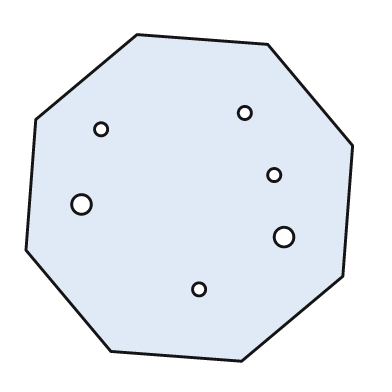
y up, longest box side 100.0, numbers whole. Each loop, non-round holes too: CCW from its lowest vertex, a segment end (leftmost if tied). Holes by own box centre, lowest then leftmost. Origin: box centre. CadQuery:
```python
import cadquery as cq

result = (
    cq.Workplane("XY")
    .moveTo(16.0, -50.0)
    .lineTo(47.0, -24.0)
    .lineTo(50.0, 16.0)
    .lineTo(24.0, 47.0)
    .lineTo(-16.0, 50.0)
    .lineTo(-47.0, 24.0)
    .lineTo(-50.0, -16.0)
    .lineTo(-24.0, -47.0)
    .close()
    .moveTo(3.0, -28.0)
    .circle(2.0)
    .moveTo(29.0, -12.0)
    .circle(3.0)
    .moveTo(-33.0, -2.0)
    .circle(3.0)
    .moveTo(26.0, 7.0)
    .circle(2.0)
    .moveTo(-27.0, 21.0)
    .circle(2.0)
    .moveTo(17.0, 26.0)
    .circle(2.0)
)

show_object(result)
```